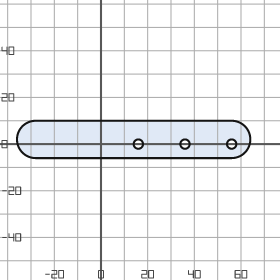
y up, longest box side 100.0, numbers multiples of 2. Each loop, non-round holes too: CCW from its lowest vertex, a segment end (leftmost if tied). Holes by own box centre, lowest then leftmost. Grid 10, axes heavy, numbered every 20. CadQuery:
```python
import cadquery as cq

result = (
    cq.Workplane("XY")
    .moveTo(-28.0, -6.0)
    .lineTo(56.0, -6.0)
    .threePointArc((64.0, 2.0), (56.0, 10.0))
    .lineTo(-28.0, 10.0)
    .threePointArc((-36.0, 2.0), (-28.0, -6.0))
    .close()
    .moveTo(16.0, 0.0)
    .circle(2.0)
    .moveTo(36.0, 0.0)
    .circle(2.0)
    .moveTo(56.0, 0.0)
    .circle(2.0)
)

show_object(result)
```